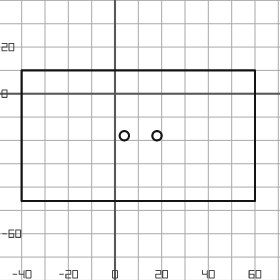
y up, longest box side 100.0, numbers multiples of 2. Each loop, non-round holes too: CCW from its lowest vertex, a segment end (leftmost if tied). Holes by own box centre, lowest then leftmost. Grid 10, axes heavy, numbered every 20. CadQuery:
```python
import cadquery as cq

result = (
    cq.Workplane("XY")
    .moveTo(-40.0, -46.0)
    .lineTo(60.0, -46.0)
    .lineTo(60.0, 10.0)
    .lineTo(-40.0, 10.0)
    .close()
    .moveTo(4.0, -18.0)
    .circle(2.0)
    .moveTo(18.0, -18.0)
    .circle(2.0)
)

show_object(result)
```